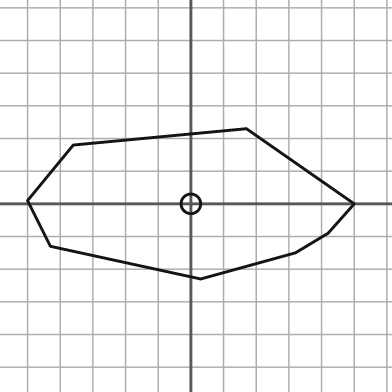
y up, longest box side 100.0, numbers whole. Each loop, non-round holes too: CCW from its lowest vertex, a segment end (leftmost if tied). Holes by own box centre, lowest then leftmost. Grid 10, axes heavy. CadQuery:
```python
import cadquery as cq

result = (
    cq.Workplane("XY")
    .moveTo(3.0, -23.0)
    .lineTo(32.0, -15.0)
    .lineTo(42.0, -9.0)
    .lineTo(50.0, 0.0)
    .lineTo(17.0, 23.0)
    .lineTo(-36.0, 18.0)
    .lineTo(-50.0, 1.0)
    .lineTo(-43.0, -13.0)
    .close()
    .moveTo(0.0, 0.0)
    .circle(3.0)
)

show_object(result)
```